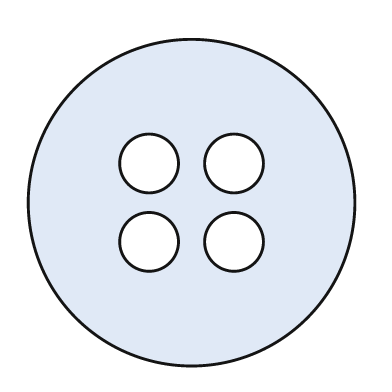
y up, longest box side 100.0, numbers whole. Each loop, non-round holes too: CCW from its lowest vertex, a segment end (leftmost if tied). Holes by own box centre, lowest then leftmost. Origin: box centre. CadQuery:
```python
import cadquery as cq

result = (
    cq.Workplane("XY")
    .moveTo(0.0, 0.0)
    .circle(50.0)
    .moveTo(-13.0, -12.0)
    .circle(9.0)
    .moveTo(13.0, -12.0)
    .circle(9.0)
    .moveTo(-13.0, 12.0)
    .circle(9.0)
    .moveTo(13.0, 12.0)
    .circle(9.0)
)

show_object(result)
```